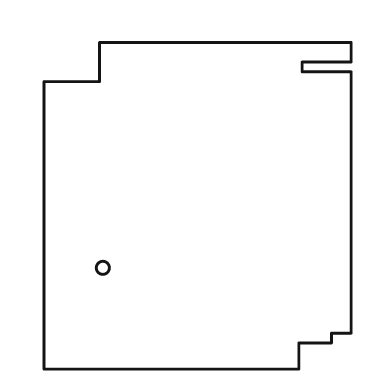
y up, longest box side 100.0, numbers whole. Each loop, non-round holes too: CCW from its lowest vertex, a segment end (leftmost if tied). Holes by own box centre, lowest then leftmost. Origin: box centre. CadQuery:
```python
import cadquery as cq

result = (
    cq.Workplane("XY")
    .moveTo(-47.0, -50.0)
    .lineTo(31.0, -50.0)
    .lineTo(31.0, -42.0)
    .lineTo(41.0, -42.0)
    .lineTo(41.0, -39.0)
    .lineTo(47.0, -39.0)
    .lineTo(47.0, 41.0)
    .lineTo(32.0, 41.0)
    .lineTo(32.0, 44.0)
    .lineTo(47.0, 44.0)
    .lineTo(47.0, 50.0)
    .lineTo(-30.0, 50.0)
    .lineTo(-30.0, 38.0)
    .lineTo(-47.0, 38.0)
    .close()
    .moveTo(-29.0, -19.0)
    .circle(2.0)
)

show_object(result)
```